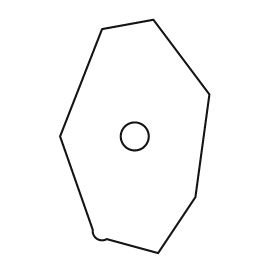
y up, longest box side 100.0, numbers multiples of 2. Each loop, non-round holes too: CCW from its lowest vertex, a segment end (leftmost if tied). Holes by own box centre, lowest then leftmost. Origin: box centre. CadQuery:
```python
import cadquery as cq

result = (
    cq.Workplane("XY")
    .moveTo(10.0, -50.0)
    .lineTo(26.0, -26.0)
    .lineTo(32.0, 18.0)
    .lineTo(8.0, 50.0)
    .lineTo(-14.0, 46.0)
    .lineTo(-32.0, 0.0)
    .lineTo(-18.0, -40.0)
    .threePointArc((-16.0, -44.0), (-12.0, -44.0))
    .close()
    .moveTo(0.0, 0.0)
    .circle(6.0)
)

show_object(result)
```